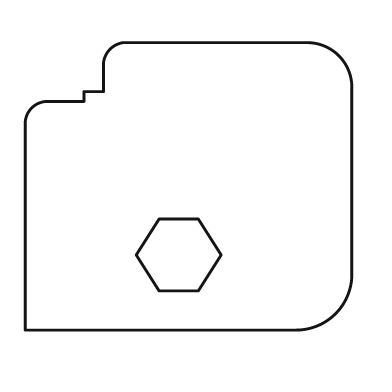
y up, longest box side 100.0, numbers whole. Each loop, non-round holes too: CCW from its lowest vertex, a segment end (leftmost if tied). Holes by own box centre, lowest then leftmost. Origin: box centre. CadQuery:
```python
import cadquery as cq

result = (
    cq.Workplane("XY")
    .moveTo(-50.0, -44.0)
    .lineTo(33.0, -44.0)
    .threePointArc((45.0, -39.0), (50.0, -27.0))
    .lineTo(50.0, 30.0)
    .threePointArc((46.0, 40.0), (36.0, 44.0))
    .lineTo(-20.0, 44.0)
    .threePointArc((-24.0, 42.0), (-26.0, 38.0))
    .lineTo(-26.0, 29.0)
    .lineTo(-32.0, 29.0)
    .lineTo(-32.0, 26.0)
    .lineTo(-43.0, 26.0)
    .threePointArc((-48.0, 24.0), (-50.0, 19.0))
    .close()
    .moveTo(-9.0, -32.0)
    .lineTo(3.0, -32.0)
    .lineTo(10.0, -21.0)
    .lineTo(3.0, -10.0)
    .lineTo(-9.0, -10.0)
    .lineTo(-16.0, -21.0)
    .close()
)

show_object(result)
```